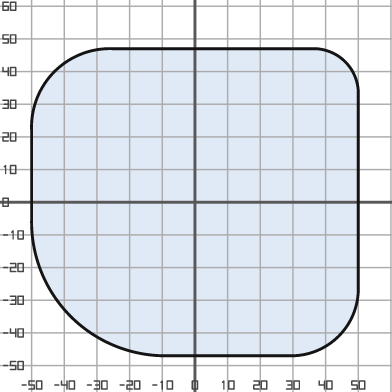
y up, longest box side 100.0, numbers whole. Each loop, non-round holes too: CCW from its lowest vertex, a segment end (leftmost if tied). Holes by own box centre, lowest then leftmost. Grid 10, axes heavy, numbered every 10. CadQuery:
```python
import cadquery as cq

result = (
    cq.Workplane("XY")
    .moveTo(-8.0, -47.0)
    .lineTo(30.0, -47.0)
    .threePointArc((44.0, -41.0), (50.0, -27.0))
    .lineTo(50.0, 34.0)
    .threePointArc((46.0, 43.0), (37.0, 47.0))
    .lineTo(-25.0, 47.0)
    .threePointArc((-43.0, 40.0), (-50.0, 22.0))
    .lineTo(-50.0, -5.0)
    .threePointArc((-38.0, -35.0), (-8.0, -47.0))
    .close()
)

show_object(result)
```